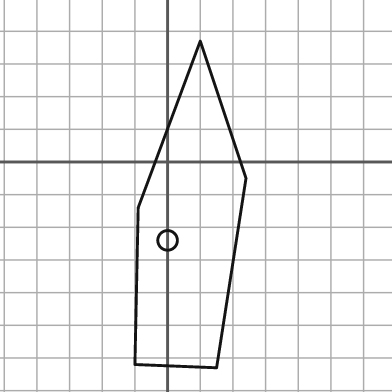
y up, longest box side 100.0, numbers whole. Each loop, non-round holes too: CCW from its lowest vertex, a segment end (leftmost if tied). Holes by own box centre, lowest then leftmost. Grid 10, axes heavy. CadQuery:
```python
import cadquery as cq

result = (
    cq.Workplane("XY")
    .moveTo(15.0, -63.0)
    .lineTo(24.0, -5.0)
    .lineTo(10.0, 37.0)
    .lineTo(-9.0, -14.0)
    .lineTo(-10.0, -62.0)
    .close()
    .moveTo(0.0, -24.0)
    .circle(3.0)
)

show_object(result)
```